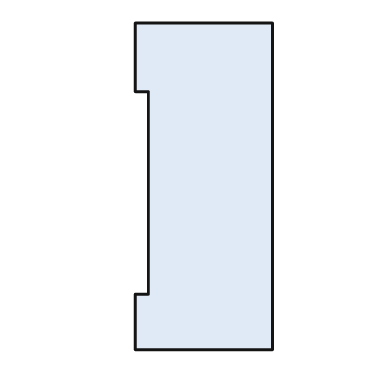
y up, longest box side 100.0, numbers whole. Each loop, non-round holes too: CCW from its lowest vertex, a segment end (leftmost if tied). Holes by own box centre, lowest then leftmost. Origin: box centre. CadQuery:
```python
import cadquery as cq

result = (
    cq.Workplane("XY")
    .moveTo(-21.0, -50.0)
    .lineTo(21.0, -50.0)
    .lineTo(21.0, 50.0)
    .lineTo(-21.0, 50.0)
    .lineTo(-21.0, 29.0)
    .lineTo(-17.0, 29.0)
    .lineTo(-17.0, -33.0)
    .lineTo(-21.0, -33.0)
    .close()
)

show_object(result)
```